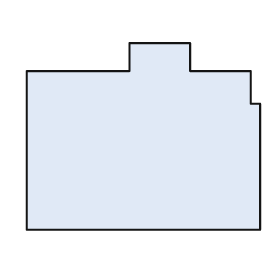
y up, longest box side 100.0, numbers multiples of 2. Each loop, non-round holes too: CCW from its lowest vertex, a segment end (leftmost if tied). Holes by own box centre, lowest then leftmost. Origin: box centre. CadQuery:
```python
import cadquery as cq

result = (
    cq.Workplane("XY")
    .moveTo(-50.0, -40.0)
    .lineTo(50.0, -40.0)
    .lineTo(50.0, 14.0)
    .lineTo(46.0, 14.0)
    .lineTo(46.0, 28.0)
    .lineTo(20.0, 28.0)
    .lineTo(20.0, 40.0)
    .lineTo(-6.0, 40.0)
    .lineTo(-6.0, 28.0)
    .lineTo(-50.0, 28.0)
    .close()
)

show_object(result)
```